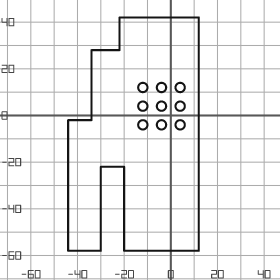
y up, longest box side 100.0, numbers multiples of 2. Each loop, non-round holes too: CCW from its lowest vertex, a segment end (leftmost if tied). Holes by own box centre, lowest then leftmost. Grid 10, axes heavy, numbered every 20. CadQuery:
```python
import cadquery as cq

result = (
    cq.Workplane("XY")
    .moveTo(-44.0, -58.0)
    .lineTo(-30.0, -58.0)
    .lineTo(-30.0, -22.0)
    .lineTo(-20.0, -22.0)
    .lineTo(-20.0, -58.0)
    .lineTo(12.0, -58.0)
    .lineTo(12.0, 42.0)
    .lineTo(-22.0, 42.0)
    .lineTo(-22.0, 28.0)
    .lineTo(-34.0, 28.0)
    .lineTo(-34.0, -2.0)
    .lineTo(-44.0, -2.0)
    .close()
    .moveTo(-12.0, -4.0)
    .circle(2.0)
    .moveTo(-4.0, -4.0)
    .circle(2.0)
    .moveTo(4.0, -4.0)
    .circle(2.0)
    .moveTo(-12.0, 4.0)
    .circle(2.0)
    .moveTo(-4.0, 4.0)
    .circle(2.0)
    .moveTo(4.0, 4.0)
    .circle(2.0)
    .moveTo(-12.0, 12.0)
    .circle(2.0)
    .moveTo(-4.0, 12.0)
    .circle(2.0)
    .moveTo(4.0, 12.0)
    .circle(2.0)
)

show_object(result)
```